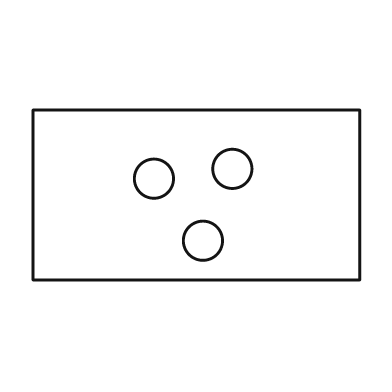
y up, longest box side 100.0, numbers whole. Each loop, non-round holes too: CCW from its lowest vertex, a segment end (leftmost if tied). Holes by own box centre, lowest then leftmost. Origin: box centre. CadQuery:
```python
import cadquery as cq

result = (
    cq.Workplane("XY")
    .moveTo(-50.0, -26.0)
    .lineTo(50.0, -26.0)
    .lineTo(50.0, 26.0)
    .lineTo(-50.0, 26.0)
    .close()
    .moveTo(2.0, -14.0)
    .circle(6.0)
    .moveTo(-13.0, 5.0)
    .circle(6.0)
    .moveTo(11.0, 8.0)
    .circle(6.0)
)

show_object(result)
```